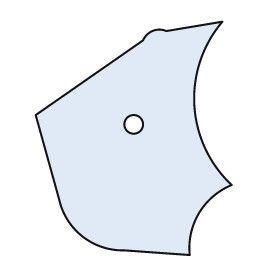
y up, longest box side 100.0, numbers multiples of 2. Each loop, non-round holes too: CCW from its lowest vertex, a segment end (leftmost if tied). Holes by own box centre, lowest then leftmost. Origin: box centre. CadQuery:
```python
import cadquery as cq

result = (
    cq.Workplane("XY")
    .moveTo(24.0, -50.0)
    .threePointArc((28.0, -32.0), (42.0, -20.0))
    .threePointArc((26.0, 14.0), (38.0, 50.0))
    .lineTo(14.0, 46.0)
    .threePointArc((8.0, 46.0), (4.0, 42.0))
    .lineTo(-42.0, 10.0)
    .lineTo(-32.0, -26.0)
    .threePointArc((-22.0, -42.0), (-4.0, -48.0))
    .close()
    .moveTo(0.0, 6.0)
    .circle(4.0)
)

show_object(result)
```